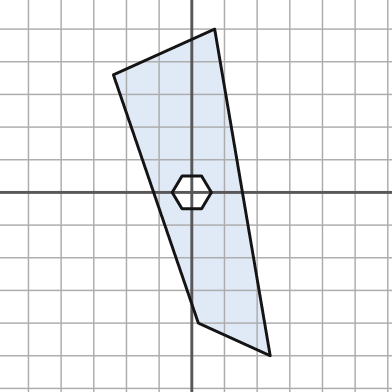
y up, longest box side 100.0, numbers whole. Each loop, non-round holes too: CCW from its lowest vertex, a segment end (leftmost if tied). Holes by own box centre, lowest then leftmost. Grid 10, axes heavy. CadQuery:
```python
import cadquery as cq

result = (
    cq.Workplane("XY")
    .moveTo(24.0, -50.0)
    .lineTo(7.0, 50.0)
    .lineTo(-24.0, 36.0)
    .lineTo(2.0, -40.0)
    .close()
    .moveTo(-3.0, -5.0)
    .lineTo(3.0, -5.0)
    .lineTo(6.0, 0.0)
    .lineTo(3.0, 5.0)
    .lineTo(-3.0, 5.0)
    .lineTo(-6.0, 0.0)
    .close()
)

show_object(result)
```